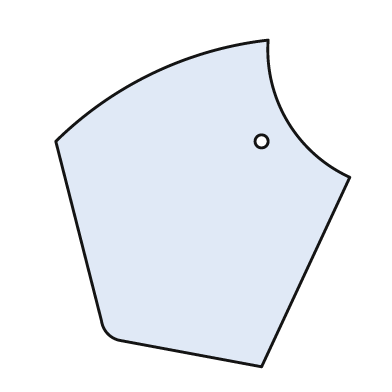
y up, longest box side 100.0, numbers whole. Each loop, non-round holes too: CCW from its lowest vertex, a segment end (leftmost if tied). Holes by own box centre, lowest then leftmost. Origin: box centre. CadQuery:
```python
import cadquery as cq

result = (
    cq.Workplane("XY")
    .moveTo(18.0, -50.0)
    .lineTo(45.0, 8.0)
    .threePointArc((26.0, 25.0), (20.0, 50.0))
    .threePointArc((-15.0, 40.0), (-45.0, 19.0))
    .lineTo(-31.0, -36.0)
    .threePointArc((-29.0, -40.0), (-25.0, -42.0))
    .close()
    .moveTo(18.0, 19.0)
    .circle(2.0)
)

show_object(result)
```